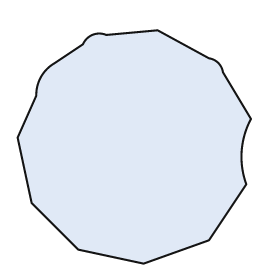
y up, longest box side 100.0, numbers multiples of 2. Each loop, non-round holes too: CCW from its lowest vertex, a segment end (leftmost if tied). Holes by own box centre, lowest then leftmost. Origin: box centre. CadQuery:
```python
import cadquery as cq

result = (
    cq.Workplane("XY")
    .moveTo(4.0, -50.0)
    .lineTo(32.0, -40.0)
    .lineTo(48.0, -16.0)
    .threePointArc((46.0, -2.0), (50.0, 12.0))
    .lineTo(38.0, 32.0)
    .threePointArc((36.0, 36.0), (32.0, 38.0))
    .lineTo(10.0, 50.0)
    .lineTo(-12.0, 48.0)
    .threePointArc((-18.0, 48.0), (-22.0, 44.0))
    .lineTo(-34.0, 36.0)
    .threePointArc((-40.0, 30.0), (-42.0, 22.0))
    .lineTo(-50.0, 4.0)
    .lineTo(-44.0, -24.0)
    .lineTo(-24.0, -44.0)
    .close()
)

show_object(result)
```